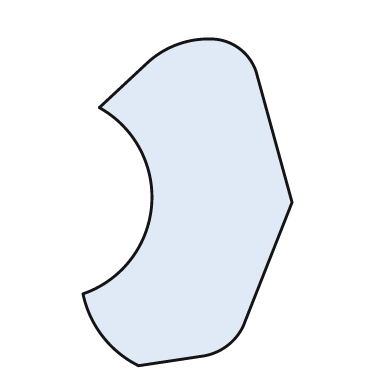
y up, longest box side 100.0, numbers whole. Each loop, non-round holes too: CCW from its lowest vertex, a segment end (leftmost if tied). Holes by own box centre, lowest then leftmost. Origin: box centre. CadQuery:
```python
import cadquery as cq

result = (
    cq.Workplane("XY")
    .moveTo(-15.0, -50.0)
    .lineTo(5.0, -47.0)
    .threePointArc((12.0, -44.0), (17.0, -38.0))
    .lineTo(32.0, 0.0)
    .lineTo(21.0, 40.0)
    .threePointArc((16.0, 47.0), (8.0, 50.0))
    .lineTo(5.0, 50.0)
    .threePointArc((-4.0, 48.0), (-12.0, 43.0))
    .lineTo(-27.0, 29.0)
    .threePointArc((-11.0, -1.0), (-32.0, -28.0))
    .threePointArc((-26.0, -41.0), (-15.0, -50.0))
    .close()
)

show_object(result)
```